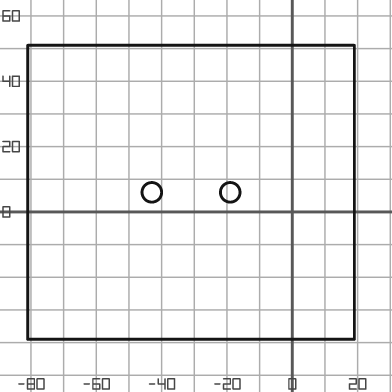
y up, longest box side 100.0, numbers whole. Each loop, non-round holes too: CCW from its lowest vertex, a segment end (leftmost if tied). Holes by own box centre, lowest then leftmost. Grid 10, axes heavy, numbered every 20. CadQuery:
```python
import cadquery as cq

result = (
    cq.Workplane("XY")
    .moveTo(-81.0, -39.0)
    .lineTo(19.0, -39.0)
    .lineTo(19.0, 51.0)
    .lineTo(-81.0, 51.0)
    .close()
    .moveTo(-43.0, 6.0)
    .circle(3.0)
    .moveTo(-19.0, 6.0)
    .circle(3.0)
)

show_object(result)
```